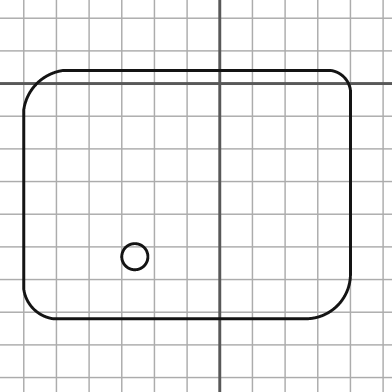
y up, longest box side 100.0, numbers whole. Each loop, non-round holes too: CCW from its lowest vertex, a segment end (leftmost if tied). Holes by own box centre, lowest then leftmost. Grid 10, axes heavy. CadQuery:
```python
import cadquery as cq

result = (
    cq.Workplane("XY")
    .moveTo(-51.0, -72.0)
    .lineTo(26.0, -72.0)
    .threePointArc((36.0, -68.0), (40.0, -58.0))
    .lineTo(40.0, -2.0)
    .threePointArc((38.0, 2.0), (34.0, 4.0))
    .lineTo(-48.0, 4.0)
    .threePointArc((-56.0, 0.0), (-60.0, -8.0))
    .lineTo(-60.0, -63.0)
    .threePointArc((-57.0, -69.0), (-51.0, -72.0))
    .close()
    .moveTo(-26.0, -53.0)
    .circle(4.0)
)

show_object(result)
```